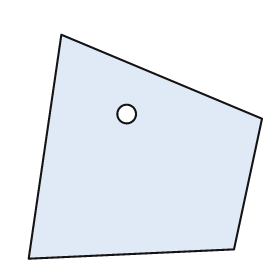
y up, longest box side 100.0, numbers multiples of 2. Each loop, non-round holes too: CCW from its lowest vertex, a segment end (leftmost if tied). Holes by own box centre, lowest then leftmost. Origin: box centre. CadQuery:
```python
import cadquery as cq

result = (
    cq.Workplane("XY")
    .moveTo(-50.0, -48.0)
    .lineTo(38.0, -44.0)
    .lineTo(50.0, 12.0)
    .lineTo(-36.0, 48.0)
    .close()
    .moveTo(-8.0, 14.0)
    .circle(4.0)
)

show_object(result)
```